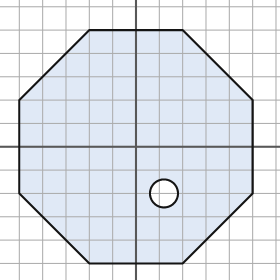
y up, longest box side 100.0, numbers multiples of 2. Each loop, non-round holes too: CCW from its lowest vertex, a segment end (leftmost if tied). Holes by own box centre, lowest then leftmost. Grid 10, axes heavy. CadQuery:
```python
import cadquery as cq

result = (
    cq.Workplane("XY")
    .moveTo(-20.0, -50.0)
    .lineTo(20.0, -50.0)
    .lineTo(50.0, -20.0)
    .lineTo(50.0, 20.0)
    .lineTo(20.0, 50.0)
    .lineTo(-20.0, 50.0)
    .lineTo(-50.0, 20.0)
    .lineTo(-50.0, -20.0)
    .close()
    .moveTo(12.0, -20.0)
    .circle(6.0)
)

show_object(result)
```